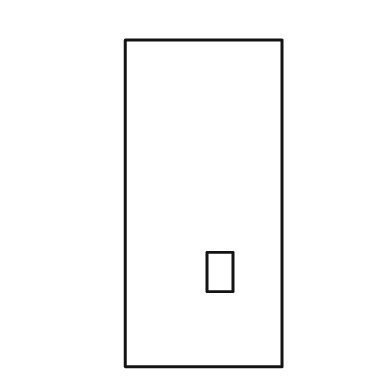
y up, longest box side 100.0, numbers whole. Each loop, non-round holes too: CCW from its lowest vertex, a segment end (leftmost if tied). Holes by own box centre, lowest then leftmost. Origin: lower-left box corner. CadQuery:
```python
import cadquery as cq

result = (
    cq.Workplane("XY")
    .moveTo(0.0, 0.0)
    .lineTo(48.0, 0.0)
    .lineTo(48.0, 100.0)
    .lineTo(0.0, 100.0)
    .close()
    .moveTo(25.0, 23.0)
    .lineTo(33.0, 23.0)
    .lineTo(33.0, 35.0)
    .lineTo(25.0, 35.0)
    .close()
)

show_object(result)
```